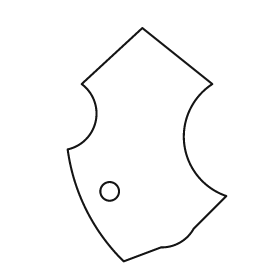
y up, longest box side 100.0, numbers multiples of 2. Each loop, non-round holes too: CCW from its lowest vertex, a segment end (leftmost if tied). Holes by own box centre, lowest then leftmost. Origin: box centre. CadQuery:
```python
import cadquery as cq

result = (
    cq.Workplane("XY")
    .moveTo(-10.0, -50.0)
    .lineTo(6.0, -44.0)
    .threePointArc((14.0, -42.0), (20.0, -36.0))
    .lineTo(34.0, -22.0)
    .threePointArc((16.0, 0.0), (28.0, 26.0))
    .lineTo(-2.0, 50.0)
    .lineTo(-28.0, 26.0)
    .threePointArc((-22.0, 10.0), (-34.0, -2.0))
    .threePointArc((-26.0, -28.0), (-10.0, -50.0))
    .close()
    .moveTo(-16.0, -20.0)
    .circle(4.0)
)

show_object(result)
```